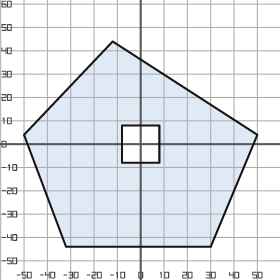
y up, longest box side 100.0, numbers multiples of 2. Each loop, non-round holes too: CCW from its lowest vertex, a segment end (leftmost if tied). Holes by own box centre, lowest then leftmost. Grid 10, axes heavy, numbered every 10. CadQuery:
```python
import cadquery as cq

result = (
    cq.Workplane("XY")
    .moveTo(-32.0, -44.0)
    .lineTo(30.0, -44.0)
    .lineTo(50.0, 4.0)
    .lineTo(-12.0, 44.0)
    .lineTo(-50.0, 4.0)
    .close()
    .moveTo(-8.0, -8.0)
    .lineTo(8.0, -8.0)
    .lineTo(8.0, 8.0)
    .lineTo(-8.0, 8.0)
    .close()
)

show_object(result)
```